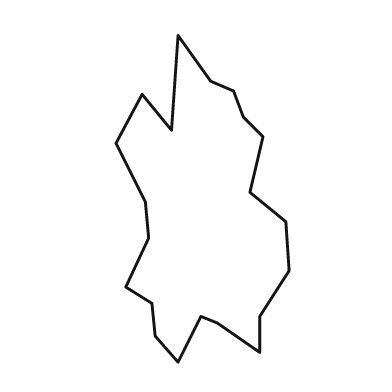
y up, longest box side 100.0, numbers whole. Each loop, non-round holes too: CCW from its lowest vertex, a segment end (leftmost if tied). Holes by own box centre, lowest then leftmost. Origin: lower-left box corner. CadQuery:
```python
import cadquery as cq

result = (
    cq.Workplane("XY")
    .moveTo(19.0, 0.0)
    .lineTo(26.0, 14.0)
    .lineTo(31.0, 12.0)
    .lineTo(44.0, 3.0)
    .lineTo(44.0, 14.0)
    .lineTo(53.0, 28.0)
    .lineTo(52.0, 43.0)
    .lineTo(41.0, 52.0)
    .lineTo(45.0, 69.0)
    .lineTo(39.0, 75.0)
    .lineTo(36.0, 83.0)
    .lineTo(29.0, 86.0)
    .lineTo(19.0, 100.0)
    .lineTo(17.0, 71.0)
    .lineTo(8.0, 82.0)
    .lineTo(0.0, 67.0)
    .lineTo(9.0, 49.0)
    .lineTo(10.0, 38.0)
    .lineTo(3.0, 23.0)
    .lineTo(11.0, 18.0)
    .lineTo(12.0, 8.0)
    .close()
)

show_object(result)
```